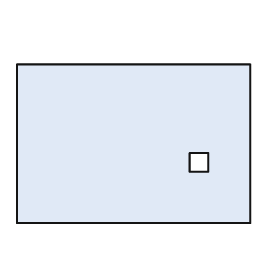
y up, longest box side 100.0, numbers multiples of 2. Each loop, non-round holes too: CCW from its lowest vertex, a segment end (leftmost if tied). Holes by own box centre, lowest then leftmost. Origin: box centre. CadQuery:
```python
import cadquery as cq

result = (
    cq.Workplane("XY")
    .moveTo(-50.0, -34.0)
    .lineTo(50.0, -34.0)
    .lineTo(50.0, 34.0)
    .lineTo(-50.0, 34.0)
    .close()
    .moveTo(24.0, -12.0)
    .lineTo(32.0, -12.0)
    .lineTo(32.0, -4.0)
    .lineTo(24.0, -4.0)
    .close()
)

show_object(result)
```